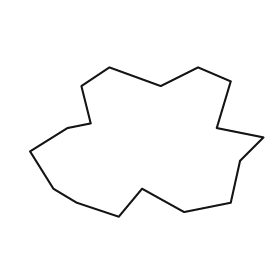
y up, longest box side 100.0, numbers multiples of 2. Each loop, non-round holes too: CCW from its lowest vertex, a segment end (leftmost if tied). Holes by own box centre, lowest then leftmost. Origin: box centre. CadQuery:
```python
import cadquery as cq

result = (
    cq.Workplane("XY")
    .moveTo(-12.0, -32.0)
    .lineTo(-2.0, -20.0)
    .lineTo(16.0, -30.0)
    .lineTo(36.0, -26.0)
    .lineTo(40.0, -8.0)
    .lineTo(50.0, 2.0)
    .lineTo(30.0, 6.0)
    .lineTo(36.0, 26.0)
    .lineTo(22.0, 32.0)
    .lineTo(6.0, 24.0)
    .lineTo(-16.0, 32.0)
    .lineTo(-28.0, 24.0)
    .lineTo(-24.0, 8.0)
    .lineTo(-34.0, 6.0)
    .lineTo(-50.0, -4.0)
    .lineTo(-40.0, -20.0)
    .lineTo(-30.0, -26.0)
    .close()
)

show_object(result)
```